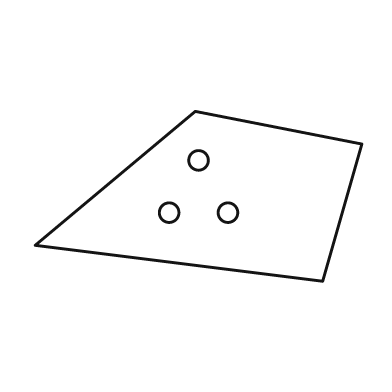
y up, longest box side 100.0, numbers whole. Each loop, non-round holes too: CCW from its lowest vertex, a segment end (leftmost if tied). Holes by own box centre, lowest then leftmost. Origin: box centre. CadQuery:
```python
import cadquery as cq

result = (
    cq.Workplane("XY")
    .moveTo(38.0, -26.0)
    .lineTo(50.0, 16.0)
    .lineTo(-1.0, 26.0)
    .lineTo(-50.0, -15.0)
    .close()
    .moveTo(-9.0, -5.0)
    .circle(3.0)
    .moveTo(9.0, -5.0)
    .circle(3.0)
    .moveTo(0.0, 11.0)
    .circle(3.0)
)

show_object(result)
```